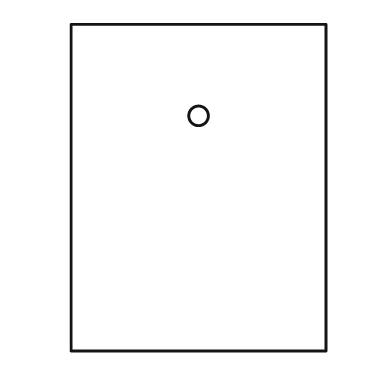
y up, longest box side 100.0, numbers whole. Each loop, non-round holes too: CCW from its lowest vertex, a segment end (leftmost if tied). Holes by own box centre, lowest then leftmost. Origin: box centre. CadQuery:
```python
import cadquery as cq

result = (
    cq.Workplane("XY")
    .moveTo(-39.0, -50.0)
    .lineTo(39.0, -50.0)
    .lineTo(39.0, 50.0)
    .lineTo(-39.0, 50.0)
    .close()
    .moveTo(0.0, 22.0)
    .circle(3.0)
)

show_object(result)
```